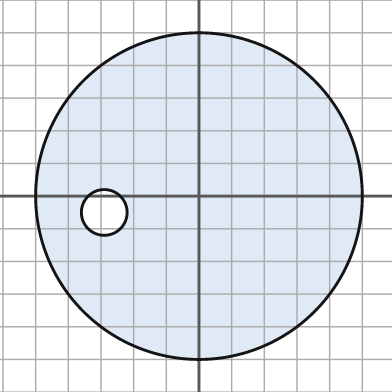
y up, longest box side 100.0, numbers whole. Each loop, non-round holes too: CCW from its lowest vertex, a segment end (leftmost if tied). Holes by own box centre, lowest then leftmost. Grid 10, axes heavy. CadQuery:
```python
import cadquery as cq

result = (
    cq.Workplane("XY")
    .moveTo(0.0, 0.0)
    .circle(50.0)
    .moveTo(-29.0, -5.0)
    .circle(7.0)
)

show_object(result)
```